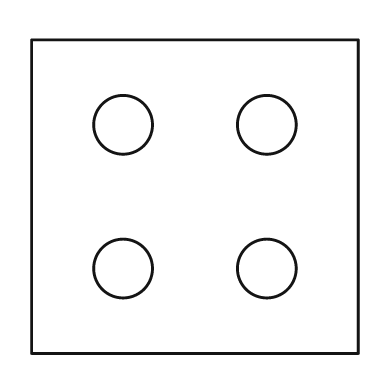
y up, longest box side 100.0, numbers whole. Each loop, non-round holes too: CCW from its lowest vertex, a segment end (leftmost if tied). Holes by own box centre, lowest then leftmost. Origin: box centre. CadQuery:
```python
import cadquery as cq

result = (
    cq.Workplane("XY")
    .moveTo(-50.0, -48.0)
    .lineTo(50.0, -48.0)
    .lineTo(50.0, 48.0)
    .lineTo(-50.0, 48.0)
    .close()
    .moveTo(-22.0, -22.0)
    .circle(9.0)
    .moveTo(22.0, -22.0)
    .circle(9.0)
    .moveTo(-22.0, 22.0)
    .circle(9.0)
    .moveTo(22.0, 22.0)
    .circle(9.0)
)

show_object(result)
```